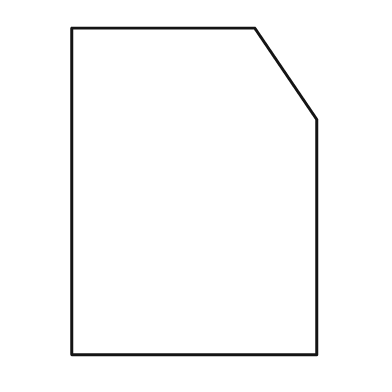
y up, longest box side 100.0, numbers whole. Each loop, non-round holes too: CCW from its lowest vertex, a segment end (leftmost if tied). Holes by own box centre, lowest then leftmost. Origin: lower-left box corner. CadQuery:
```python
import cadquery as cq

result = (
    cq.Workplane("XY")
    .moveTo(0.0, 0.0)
    .lineTo(75.0, 0.0)
    .lineTo(75.0, 72.0)
    .lineTo(56.0, 100.0)
    .lineTo(0.0, 100.0)
    .close()
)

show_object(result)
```